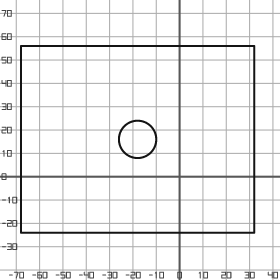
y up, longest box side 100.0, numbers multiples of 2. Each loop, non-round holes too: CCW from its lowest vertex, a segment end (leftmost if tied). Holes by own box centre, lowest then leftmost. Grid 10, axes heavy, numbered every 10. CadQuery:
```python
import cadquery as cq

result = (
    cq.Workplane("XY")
    .moveTo(-68.0, -24.0)
    .lineTo(32.0, -24.0)
    .lineTo(32.0, 56.0)
    .lineTo(-68.0, 56.0)
    .close()
    .moveTo(-18.0, 16.0)
    .circle(8.0)
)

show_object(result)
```